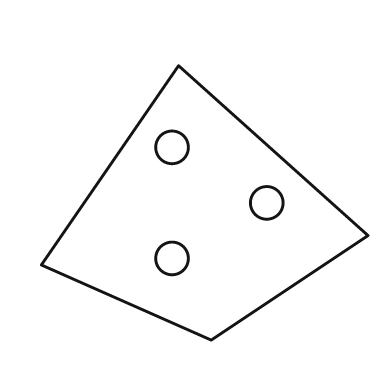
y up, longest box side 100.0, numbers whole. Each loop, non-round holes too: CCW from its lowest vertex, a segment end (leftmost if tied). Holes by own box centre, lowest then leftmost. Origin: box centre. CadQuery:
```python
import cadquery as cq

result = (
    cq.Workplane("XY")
    .moveTo(2.0, -42.0)
    .lineTo(50.0, -10.0)
    .lineTo(-8.0, 42.0)
    .lineTo(-50.0, -19.0)
    .close()
    .moveTo(-10.0, -17.0)
    .circle(5.0)
    .moveTo(19.0, 0.0)
    .circle(5.0)
    .moveTo(-10.0, 17.0)
    .circle(5.0)
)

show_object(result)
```